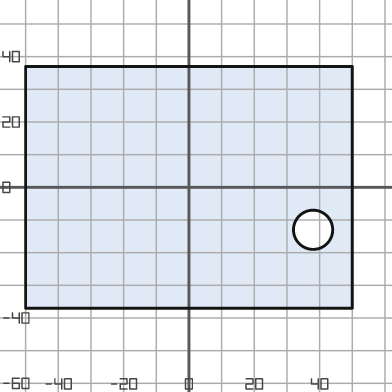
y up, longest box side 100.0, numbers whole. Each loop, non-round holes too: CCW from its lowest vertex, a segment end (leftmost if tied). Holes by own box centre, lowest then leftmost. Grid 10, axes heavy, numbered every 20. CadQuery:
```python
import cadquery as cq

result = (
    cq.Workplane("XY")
    .moveTo(-50.0, -37.0)
    .lineTo(50.0, -37.0)
    .lineTo(50.0, 37.0)
    .lineTo(-50.0, 37.0)
    .close()
    .moveTo(38.0, -13.0)
    .circle(6.0)
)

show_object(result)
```